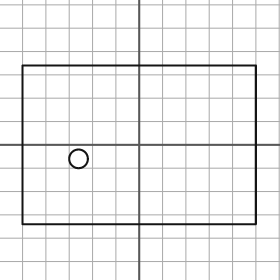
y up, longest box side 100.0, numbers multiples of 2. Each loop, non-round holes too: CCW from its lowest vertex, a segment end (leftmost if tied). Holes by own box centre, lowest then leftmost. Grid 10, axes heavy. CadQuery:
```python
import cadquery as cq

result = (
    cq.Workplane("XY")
    .moveTo(-50.0, -34.0)
    .lineTo(50.0, -34.0)
    .lineTo(50.0, 34.0)
    .lineTo(-50.0, 34.0)
    .close()
    .moveTo(-26.0, -6.0)
    .circle(4.0)
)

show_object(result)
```